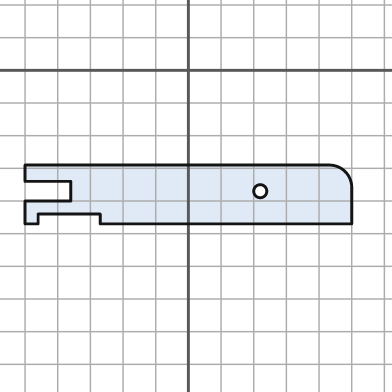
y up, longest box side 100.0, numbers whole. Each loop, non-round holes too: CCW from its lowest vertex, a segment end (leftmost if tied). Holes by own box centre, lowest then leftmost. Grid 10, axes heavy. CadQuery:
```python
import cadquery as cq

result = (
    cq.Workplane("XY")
    .moveTo(-50.0, -47.0)
    .lineTo(-46.0, -47.0)
    .lineTo(-46.0, -44.0)
    .lineTo(-27.0, -44.0)
    .lineTo(-27.0, -47.0)
    .lineTo(50.0, -47.0)
    .lineTo(50.0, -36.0)
    .threePointArc((48.0, -31.0), (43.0, -29.0))
    .lineTo(-50.0, -29.0)
    .lineTo(-50.0, -34.0)
    .lineTo(-36.0, -34.0)
    .lineTo(-36.0, -40.0)
    .lineTo(-50.0, -40.0)
    .close()
    .moveTo(22.0, -37.0)
    .circle(2.0)
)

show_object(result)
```